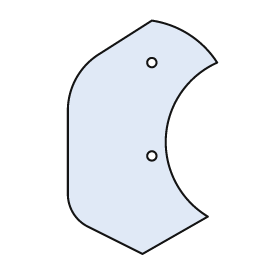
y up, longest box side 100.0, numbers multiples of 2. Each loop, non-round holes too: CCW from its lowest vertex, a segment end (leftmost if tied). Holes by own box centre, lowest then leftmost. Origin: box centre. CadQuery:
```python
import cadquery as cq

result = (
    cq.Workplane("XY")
    .moveTo(0.0, -50.0)
    .lineTo(28.0, -34.0)
    .threePointArc((10.0, 0.0), (32.0, 32.0))
    .threePointArc((20.0, 44.0), (4.0, 50.0))
    .lineTo(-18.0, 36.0)
    .threePointArc((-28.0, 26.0), (-32.0, 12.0))
    .lineTo(-32.0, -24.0)
    .threePointArc((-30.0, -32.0), (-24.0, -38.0))
    .close()
    .moveTo(4.0, -8.0)
    .circle(2.0)
    .moveTo(4.0, 32.0)
    .circle(2.0)
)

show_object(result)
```